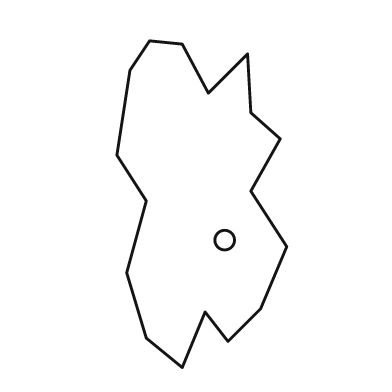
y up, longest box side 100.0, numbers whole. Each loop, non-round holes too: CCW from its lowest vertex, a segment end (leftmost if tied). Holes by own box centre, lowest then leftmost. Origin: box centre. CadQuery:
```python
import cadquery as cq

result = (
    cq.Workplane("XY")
    .moveTo(-6.0, -50.0)
    .lineTo(1.0, -33.0)
    .lineTo(8.0, -42.0)
    .lineTo(18.0, -32.0)
    .lineTo(26.0, -13.0)
    .lineTo(15.0, 4.0)
    .lineTo(24.0, 20.0)
    .lineTo(15.0, 28.0)
    .lineTo(14.0, 46.0)
    .lineTo(2.0, 34.0)
    .lineTo(-6.0, 49.0)
    .lineTo(-16.0, 50.0)
    .lineTo(-22.0, 41.0)
    .lineTo(-26.0, 15.0)
    .lineTo(-17.0, 1.0)
    .lineTo(-23.0, -21.0)
    .lineTo(-17.0, -41.0)
    .close()
    .moveTo(7.0, -11.0)
    .circle(3.0)
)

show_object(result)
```